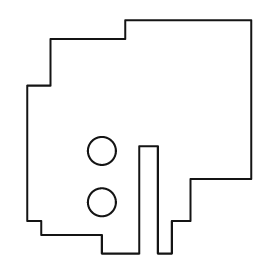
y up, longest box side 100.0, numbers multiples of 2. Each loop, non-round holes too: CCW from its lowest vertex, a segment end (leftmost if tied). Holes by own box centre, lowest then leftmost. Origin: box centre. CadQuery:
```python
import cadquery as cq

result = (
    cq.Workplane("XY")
    .moveTo(-16.0, -50.0)
    .lineTo(0.0, -50.0)
    .lineTo(0.0, -4.0)
    .lineTo(8.0, -4.0)
    .lineTo(8.0, -50.0)
    .lineTo(14.0, -50.0)
    .lineTo(14.0, -36.0)
    .lineTo(22.0, -36.0)
    .lineTo(22.0, -18.0)
    .lineTo(48.0, -18.0)
    .lineTo(48.0, 50.0)
    .lineTo(-6.0, 50.0)
    .lineTo(-6.0, 42.0)
    .lineTo(-38.0, 42.0)
    .lineTo(-38.0, 22.0)
    .lineTo(-48.0, 22.0)
    .lineTo(-48.0, -36.0)
    .lineTo(-42.0, -36.0)
    .lineTo(-42.0, -42.0)
    .lineTo(-16.0, -42.0)
    .close()
    .moveTo(-16.0, -28.0)
    .circle(6.0)
    .moveTo(-16.0, -6.0)
    .circle(6.0)
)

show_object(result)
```